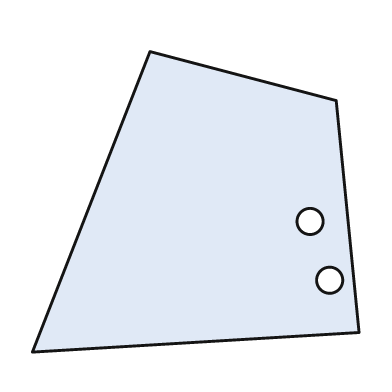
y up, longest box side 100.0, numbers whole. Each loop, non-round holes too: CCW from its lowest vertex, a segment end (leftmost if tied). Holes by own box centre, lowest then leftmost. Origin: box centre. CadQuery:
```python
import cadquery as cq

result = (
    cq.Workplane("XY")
    .moveTo(-50.0, -46.0)
    .lineTo(50.0, -40.0)
    .lineTo(43.0, 31.0)
    .lineTo(-14.0, 46.0)
    .close()
    .moveTo(41.0, -24.0)
    .circle(4.0)
    .moveTo(35.0, -6.0)
    .circle(4.0)
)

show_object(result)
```